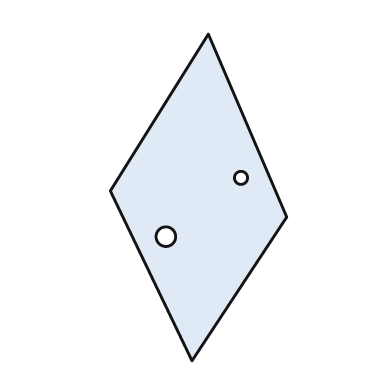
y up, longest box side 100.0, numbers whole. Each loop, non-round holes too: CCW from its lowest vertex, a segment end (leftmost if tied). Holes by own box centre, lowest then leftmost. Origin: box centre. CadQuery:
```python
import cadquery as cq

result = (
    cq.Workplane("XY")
    .moveTo(-2.0, -50.0)
    .lineTo(27.0, -6.0)
    .lineTo(3.0, 50.0)
    .lineTo(-27.0, 2.0)
    .close()
    .moveTo(-10.0, -12.0)
    .circle(3.0)
    .moveTo(13.0, 6.0)
    .circle(2.0)
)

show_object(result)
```